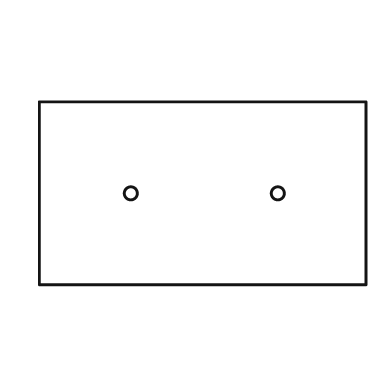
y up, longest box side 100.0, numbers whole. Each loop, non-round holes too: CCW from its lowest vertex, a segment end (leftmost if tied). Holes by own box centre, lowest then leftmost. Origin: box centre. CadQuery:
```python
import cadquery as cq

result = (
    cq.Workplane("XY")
    .moveTo(-50.0, -28.0)
    .lineTo(50.0, -28.0)
    .lineTo(50.0, 28.0)
    .lineTo(-50.0, 28.0)
    .close()
    .moveTo(-22.0, 0.0)
    .circle(2.0)
    .moveTo(23.0, 0.0)
    .circle(2.0)
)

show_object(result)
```